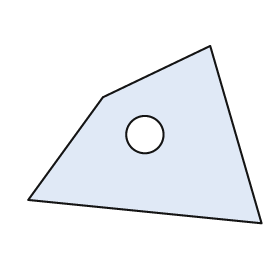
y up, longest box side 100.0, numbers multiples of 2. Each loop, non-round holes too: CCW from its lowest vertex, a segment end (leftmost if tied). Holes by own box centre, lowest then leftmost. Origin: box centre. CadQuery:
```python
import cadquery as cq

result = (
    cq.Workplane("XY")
    .moveTo(50.0, -38.0)
    .lineTo(28.0, 38.0)
    .lineTo(-18.0, 16.0)
    .lineTo(-50.0, -28.0)
    .close()
    .moveTo(0.0, 0.0)
    .circle(8.0)
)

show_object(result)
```